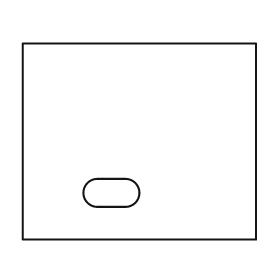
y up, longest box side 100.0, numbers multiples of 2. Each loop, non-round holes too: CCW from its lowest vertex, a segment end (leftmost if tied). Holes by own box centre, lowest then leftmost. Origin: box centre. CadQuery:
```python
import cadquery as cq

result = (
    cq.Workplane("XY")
    .moveTo(-50.0, -42.0)
    .lineTo(50.0, -42.0)
    .lineTo(50.0, 42.0)
    .lineTo(-50.0, 42.0)
    .close()
    .moveTo(-18.0, -28.0)
    .lineTo(-6.0, -28.0)
    .threePointArc((0.0, -22.0), (-6.0, -16.0))
    .lineTo(-18.0, -16.0)
    .threePointArc((-24.0, -22.0), (-18.0, -28.0))
    .close()
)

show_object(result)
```